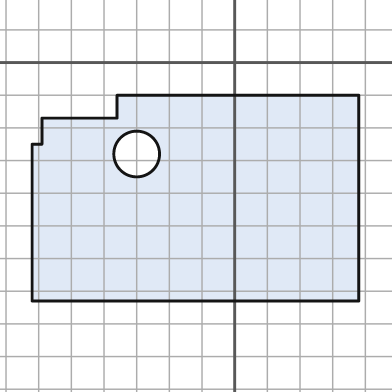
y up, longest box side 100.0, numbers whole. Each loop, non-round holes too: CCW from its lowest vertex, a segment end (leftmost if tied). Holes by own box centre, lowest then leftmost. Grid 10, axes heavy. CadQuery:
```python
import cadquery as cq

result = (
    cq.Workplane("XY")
    .moveTo(-62.0, -73.0)
    .lineTo(38.0, -73.0)
    .lineTo(38.0, -10.0)
    .lineTo(-36.0, -10.0)
    .lineTo(-36.0, -17.0)
    .lineTo(-59.0, -17.0)
    .lineTo(-59.0, -25.0)
    .lineTo(-62.0, -25.0)
    .close()
    .moveTo(-30.0, -28.0)
    .circle(7.0)
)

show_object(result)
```